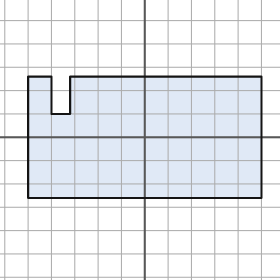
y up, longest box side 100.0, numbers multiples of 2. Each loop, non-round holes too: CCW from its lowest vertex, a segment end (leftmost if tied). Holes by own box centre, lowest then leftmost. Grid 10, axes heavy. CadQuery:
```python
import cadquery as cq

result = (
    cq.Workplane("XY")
    .moveTo(-50.0, -26.0)
    .lineTo(50.0, -26.0)
    .lineTo(50.0, 26.0)
    .lineTo(-32.0, 26.0)
    .lineTo(-32.0, 10.0)
    .lineTo(-40.0, 10.0)
    .lineTo(-40.0, 26.0)
    .lineTo(-50.0, 26.0)
    .close()
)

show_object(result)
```